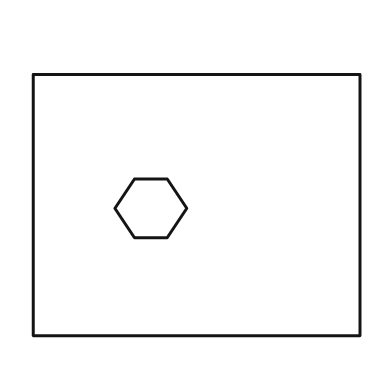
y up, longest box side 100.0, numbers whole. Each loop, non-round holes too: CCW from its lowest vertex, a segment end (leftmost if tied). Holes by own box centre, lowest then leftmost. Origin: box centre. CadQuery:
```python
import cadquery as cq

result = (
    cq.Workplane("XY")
    .moveTo(-50.0, -40.0)
    .lineTo(50.0, -40.0)
    .lineTo(50.0, 40.0)
    .lineTo(-50.0, 40.0)
    .close()
    .moveTo(-19.0, -10.0)
    .lineTo(-9.0, -10.0)
    .lineTo(-3.0, -1.0)
    .lineTo(-9.0, 8.0)
    .lineTo(-19.0, 8.0)
    .lineTo(-25.0, -1.0)
    .close()
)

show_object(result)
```